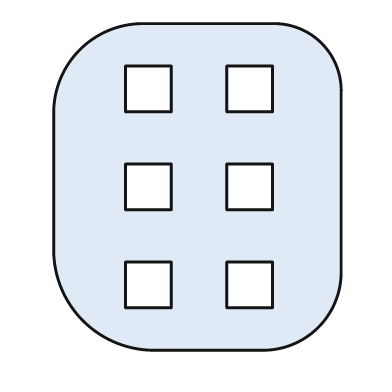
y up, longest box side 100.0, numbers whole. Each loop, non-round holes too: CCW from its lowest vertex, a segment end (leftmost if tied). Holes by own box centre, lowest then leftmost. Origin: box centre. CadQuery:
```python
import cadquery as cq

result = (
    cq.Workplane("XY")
    .moveTo(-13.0, -50.0)
    .lineTo(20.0, -50.0)
    .threePointArc((37.0, -43.0), (44.0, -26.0))
    .lineTo(44.0, 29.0)
    .threePointArc((38.0, 44.0), (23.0, 50.0))
    .lineTo(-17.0, 50.0)
    .threePointArc((-36.0, 42.0), (-44.0, 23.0))
    .lineTo(-44.0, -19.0)
    .threePointArc((-35.0, -41.0), (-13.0, -50.0))
    .close()
    .moveTo(-22.0, -37.0)
    .lineTo(-8.0, -37.0)
    .lineTo(-8.0, -23.0)
    .lineTo(-22.0, -23.0)
    .close()
    .moveTo(9.0, -37.0)
    .lineTo(23.0, -37.0)
    .lineTo(23.0, -23.0)
    .lineTo(9.0, -23.0)
    .close()
    .moveTo(-22.0, -7.0)
    .lineTo(-8.0, -7.0)
    .lineTo(-8.0, 7.0)
    .lineTo(-22.0, 7.0)
    .close()
    .moveTo(9.0, -7.0)
    .lineTo(23.0, -7.0)
    .lineTo(23.0, 7.0)
    .lineTo(9.0, 7.0)
    .close()
    .moveTo(-22.0, 23.0)
    .lineTo(-8.0, 23.0)
    .lineTo(-8.0, 37.0)
    .lineTo(-22.0, 37.0)
    .close()
    .moveTo(9.0, 23.0)
    .lineTo(23.0, 23.0)
    .lineTo(23.0, 37.0)
    .lineTo(9.0, 37.0)
    .close()
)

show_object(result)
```